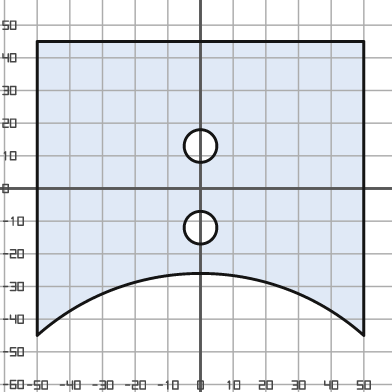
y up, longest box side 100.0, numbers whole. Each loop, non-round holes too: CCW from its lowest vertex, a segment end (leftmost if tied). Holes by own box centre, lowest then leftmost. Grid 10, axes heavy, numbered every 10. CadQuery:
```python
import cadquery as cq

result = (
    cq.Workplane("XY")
    .moveTo(-50.0, -45.0)
    .threePointArc((0.0, -26.0), (50.0, -45.0))
    .lineTo(50.0, 45.0)
    .lineTo(-50.0, 45.0)
    .close()
    .moveTo(0.0, -12.0)
    .circle(5.0)
    .moveTo(0.0, 13.0)
    .circle(5.0)
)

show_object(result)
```